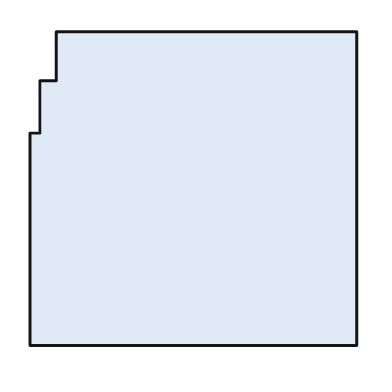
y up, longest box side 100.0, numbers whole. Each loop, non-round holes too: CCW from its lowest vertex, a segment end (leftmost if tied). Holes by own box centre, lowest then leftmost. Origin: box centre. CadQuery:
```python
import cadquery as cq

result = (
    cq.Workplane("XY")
    .moveTo(-50.0, -48.0)
    .lineTo(50.0, -48.0)
    .lineTo(50.0, 48.0)
    .lineTo(-42.0, 48.0)
    .lineTo(-42.0, 33.0)
    .lineTo(-47.0, 33.0)
    .lineTo(-47.0, 17.0)
    .lineTo(-50.0, 17.0)
    .close()
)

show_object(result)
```